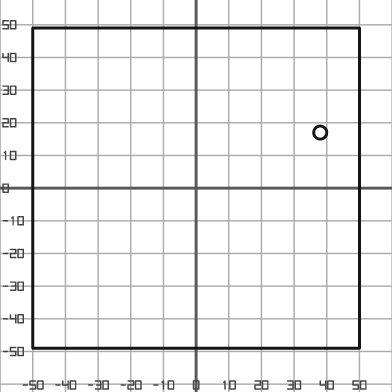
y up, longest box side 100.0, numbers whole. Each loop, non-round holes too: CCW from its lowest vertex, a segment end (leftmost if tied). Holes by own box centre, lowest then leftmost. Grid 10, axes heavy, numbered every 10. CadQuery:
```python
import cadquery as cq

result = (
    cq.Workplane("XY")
    .moveTo(-50.0, -49.0)
    .lineTo(50.0, -49.0)
    .lineTo(50.0, 49.0)
    .lineTo(-50.0, 49.0)
    .close()
    .moveTo(38.0, 17.0)
    .circle(2.0)
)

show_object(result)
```